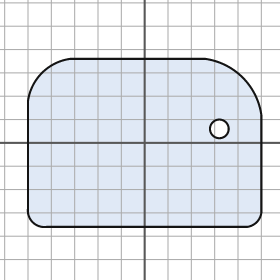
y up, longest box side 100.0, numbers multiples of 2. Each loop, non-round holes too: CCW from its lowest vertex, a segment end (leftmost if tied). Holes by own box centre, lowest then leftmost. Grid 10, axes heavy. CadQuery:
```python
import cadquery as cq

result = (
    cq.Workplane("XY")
    .moveTo(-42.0, -36.0)
    .lineTo(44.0, -36.0)
    .threePointArc((48.0, -34.0), (50.0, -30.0))
    .lineTo(50.0, 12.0)
    .threePointArc((42.0, 28.0), (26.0, 36.0))
    .lineTo(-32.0, 36.0)
    .threePointArc((-44.0, 30.0), (-50.0, 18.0))
    .lineTo(-50.0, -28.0)
    .threePointArc((-48.0, -34.0), (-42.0, -36.0))
    .close()
    .moveTo(32.0, 6.0)
    .circle(4.0)
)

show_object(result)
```